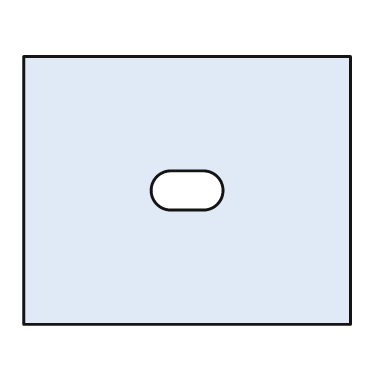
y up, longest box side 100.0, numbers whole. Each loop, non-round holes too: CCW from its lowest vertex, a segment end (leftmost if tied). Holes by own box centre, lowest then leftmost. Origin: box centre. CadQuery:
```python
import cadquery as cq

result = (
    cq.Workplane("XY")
    .moveTo(-50.0, -41.0)
    .lineTo(50.0, -41.0)
    .lineTo(50.0, 41.0)
    .lineTo(-50.0, 41.0)
    .close()
    .moveTo(-5.0, -6.0)
    .lineTo(5.0, -6.0)
    .threePointArc((11.0, 0.0), (5.0, 6.0))
    .lineTo(-5.0, 6.0)
    .threePointArc((-11.0, 0.0), (-5.0, -6.0))
    .close()
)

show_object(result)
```